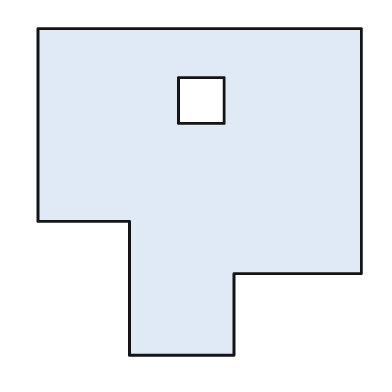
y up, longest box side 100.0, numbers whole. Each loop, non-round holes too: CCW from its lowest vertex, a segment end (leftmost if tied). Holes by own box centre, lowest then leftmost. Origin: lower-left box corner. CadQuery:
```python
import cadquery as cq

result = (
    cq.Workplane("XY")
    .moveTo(28.0, 0.0)
    .lineTo(60.0, 0.0)
    .lineTo(60.0, 25.0)
    .lineTo(99.0, 25.0)
    .lineTo(99.0, 100.0)
    .lineTo(0.0, 100.0)
    .lineTo(0.0, 41.0)
    .lineTo(28.0, 41.0)
    .close()
    .moveTo(43.0, 71.0)
    .lineTo(57.0, 71.0)
    .lineTo(57.0, 85.0)
    .lineTo(43.0, 85.0)
    .close()
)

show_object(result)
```